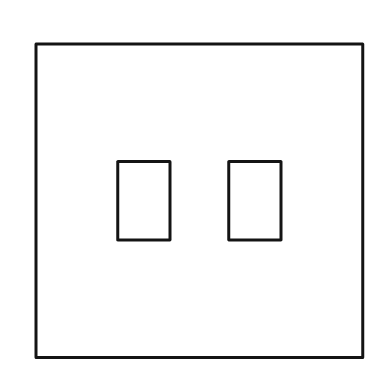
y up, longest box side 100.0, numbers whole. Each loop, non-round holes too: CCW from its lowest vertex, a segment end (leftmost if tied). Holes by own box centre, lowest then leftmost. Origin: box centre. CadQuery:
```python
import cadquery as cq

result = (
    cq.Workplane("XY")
    .moveTo(-50.0, -48.0)
    .lineTo(50.0, -48.0)
    .lineTo(50.0, 48.0)
    .lineTo(-50.0, 48.0)
    .close()
    .moveTo(-25.0, -12.0)
    .lineTo(-9.0, -12.0)
    .lineTo(-9.0, 12.0)
    .lineTo(-25.0, 12.0)
    .close()
    .moveTo(9.0, -12.0)
    .lineTo(25.0, -12.0)
    .lineTo(25.0, 12.0)
    .lineTo(9.0, 12.0)
    .close()
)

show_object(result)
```